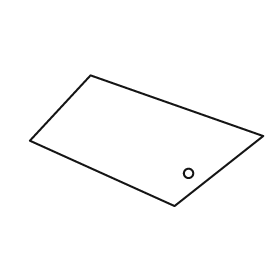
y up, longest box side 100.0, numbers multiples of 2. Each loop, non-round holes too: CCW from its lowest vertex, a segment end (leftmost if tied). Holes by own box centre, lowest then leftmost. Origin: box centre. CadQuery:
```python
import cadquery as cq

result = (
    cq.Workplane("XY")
    .moveTo(12.0, -28.0)
    .lineTo(50.0, 2.0)
    .lineTo(-24.0, 28.0)
    .lineTo(-50.0, 0.0)
    .close()
    .moveTo(18.0, -14.0)
    .circle(2.0)
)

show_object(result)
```